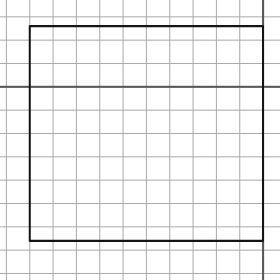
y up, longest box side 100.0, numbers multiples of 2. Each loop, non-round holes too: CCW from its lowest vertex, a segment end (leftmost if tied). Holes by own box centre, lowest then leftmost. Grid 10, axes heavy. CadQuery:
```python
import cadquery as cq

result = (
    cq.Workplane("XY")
    .moveTo(-100.0, -66.0)
    .lineTo(0.0, -66.0)
    .lineTo(0.0, 26.0)
    .lineTo(-100.0, 26.0)
    .close()
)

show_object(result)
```